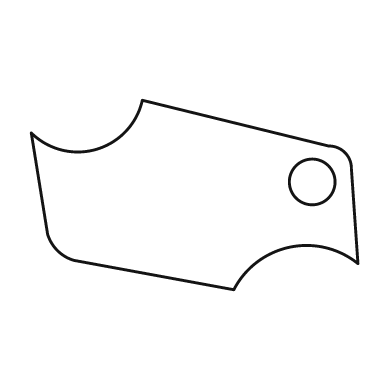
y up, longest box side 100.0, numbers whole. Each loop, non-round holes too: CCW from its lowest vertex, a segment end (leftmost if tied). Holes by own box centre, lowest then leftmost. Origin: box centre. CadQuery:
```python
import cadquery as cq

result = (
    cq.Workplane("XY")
    .moveTo(12.0, -29.0)
    .threePointArc((29.0, -16.0), (50.0, -21.0))
    .lineTo(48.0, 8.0)
    .threePointArc((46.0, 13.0), (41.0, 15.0))
    .lineTo(-16.0, 29.0)
    .threePointArc((-30.0, 14.0), (-50.0, 19.0))
    .lineTo(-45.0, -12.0)
    .threePointArc((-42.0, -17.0), (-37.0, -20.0))
    .close()
    .moveTo(36.0, 4.0)
    .circle(7.0)
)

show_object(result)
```